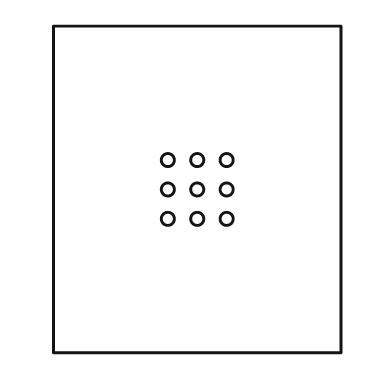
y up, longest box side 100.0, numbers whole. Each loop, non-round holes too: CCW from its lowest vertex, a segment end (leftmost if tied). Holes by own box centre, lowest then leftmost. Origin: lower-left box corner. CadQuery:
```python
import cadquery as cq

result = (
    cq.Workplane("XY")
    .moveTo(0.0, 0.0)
    .lineTo(88.0, 0.0)
    .lineTo(88.0, 100.0)
    .lineTo(0.0, 100.0)
    .close()
    .moveTo(35.0, 41.0)
    .circle(2.0)
    .moveTo(44.0, 41.0)
    .circle(2.0)
    .moveTo(53.0, 41.0)
    .circle(2.0)
    .moveTo(35.0, 50.0)
    .circle(2.0)
    .moveTo(44.0, 50.0)
    .circle(2.0)
    .moveTo(53.0, 50.0)
    .circle(2.0)
    .moveTo(35.0, 59.0)
    .circle(2.0)
    .moveTo(44.0, 59.0)
    .circle(2.0)
    .moveTo(53.0, 59.0)
    .circle(2.0)
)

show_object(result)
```